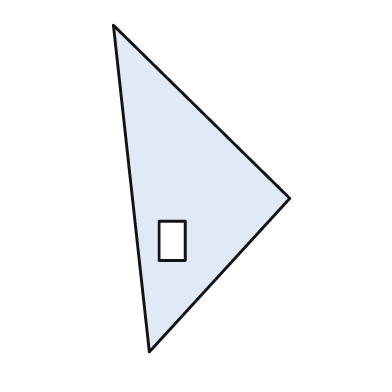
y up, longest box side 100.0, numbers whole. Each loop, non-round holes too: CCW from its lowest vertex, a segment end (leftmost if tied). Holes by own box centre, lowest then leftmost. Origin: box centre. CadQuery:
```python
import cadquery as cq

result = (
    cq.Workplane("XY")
    .moveTo(-16.0, -50.0)
    .lineTo(27.0, -3.0)
    .lineTo(-27.0, 50.0)
    .close()
    .moveTo(-13.0, -22.0)
    .lineTo(-5.0, -22.0)
    .lineTo(-5.0, -10.0)
    .lineTo(-13.0, -10.0)
    .close()
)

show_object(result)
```